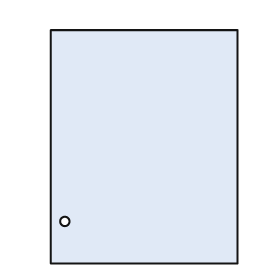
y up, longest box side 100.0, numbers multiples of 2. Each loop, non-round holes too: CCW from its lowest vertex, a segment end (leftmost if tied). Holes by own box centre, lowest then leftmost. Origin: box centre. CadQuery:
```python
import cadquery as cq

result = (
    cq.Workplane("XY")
    .moveTo(-40.0, -50.0)
    .lineTo(40.0, -50.0)
    .lineTo(40.0, 50.0)
    .lineTo(-40.0, 50.0)
    .close()
    .moveTo(-34.0, -32.0)
    .circle(2.0)
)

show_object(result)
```